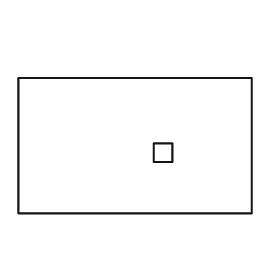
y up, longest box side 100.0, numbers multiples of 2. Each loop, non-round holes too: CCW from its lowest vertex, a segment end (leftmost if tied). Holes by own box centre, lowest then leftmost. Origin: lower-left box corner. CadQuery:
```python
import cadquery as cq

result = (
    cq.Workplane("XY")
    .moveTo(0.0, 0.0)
    .lineTo(100.0, 0.0)
    .lineTo(100.0, 58.0)
    .lineTo(0.0, 58.0)
    .close()
    .moveTo(58.0, 22.0)
    .lineTo(66.0, 22.0)
    .lineTo(66.0, 30.0)
    .lineTo(58.0, 30.0)
    .close()
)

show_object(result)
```